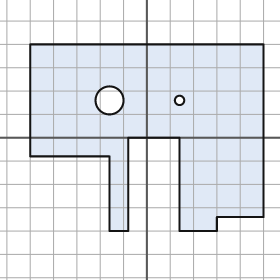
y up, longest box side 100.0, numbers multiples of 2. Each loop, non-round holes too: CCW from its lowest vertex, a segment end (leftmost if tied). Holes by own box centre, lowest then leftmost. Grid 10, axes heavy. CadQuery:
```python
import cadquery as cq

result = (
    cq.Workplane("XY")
    .moveTo(-16.0, -40.0)
    .lineTo(-8.0, -40.0)
    .lineTo(-8.0, 0.0)
    .lineTo(14.0, 0.0)
    .lineTo(14.0, -40.0)
    .lineTo(30.0, -40.0)
    .lineTo(30.0, -34.0)
    .lineTo(50.0, -34.0)
    .lineTo(50.0, 40.0)
    .lineTo(-50.0, 40.0)
    .lineTo(-50.0, -8.0)
    .lineTo(-16.0, -8.0)
    .close()
    .moveTo(-16.0, 16.0)
    .circle(6.0)
    .moveTo(14.0, 16.0)
    .circle(2.0)
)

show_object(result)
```